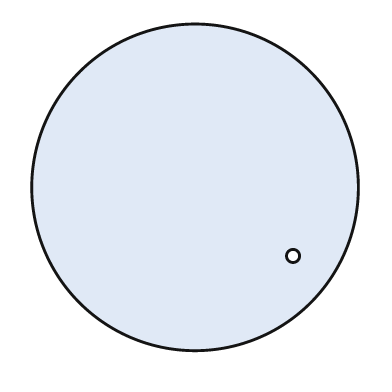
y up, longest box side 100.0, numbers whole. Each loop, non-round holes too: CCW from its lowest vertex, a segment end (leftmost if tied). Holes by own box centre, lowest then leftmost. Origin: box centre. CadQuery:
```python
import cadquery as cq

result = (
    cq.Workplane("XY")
    .moveTo(0.0, 0.0)
    .circle(50.0)
    .moveTo(30.0, -21.0)
    .circle(2.0)
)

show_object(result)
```